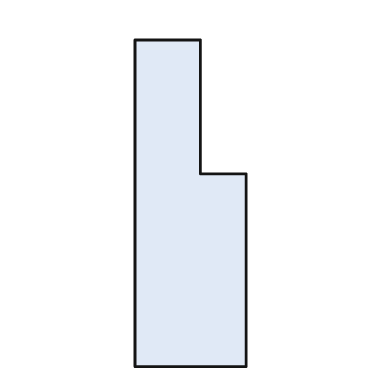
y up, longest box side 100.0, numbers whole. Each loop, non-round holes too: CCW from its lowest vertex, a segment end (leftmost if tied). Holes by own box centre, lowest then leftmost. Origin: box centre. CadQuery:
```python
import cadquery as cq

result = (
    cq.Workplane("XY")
    .moveTo(-17.0, -50.0)
    .lineTo(17.0, -50.0)
    .lineTo(17.0, 9.0)
    .lineTo(3.0, 9.0)
    .lineTo(3.0, 50.0)
    .lineTo(-17.0, 50.0)
    .close()
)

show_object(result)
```